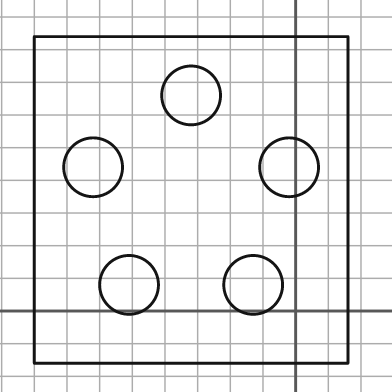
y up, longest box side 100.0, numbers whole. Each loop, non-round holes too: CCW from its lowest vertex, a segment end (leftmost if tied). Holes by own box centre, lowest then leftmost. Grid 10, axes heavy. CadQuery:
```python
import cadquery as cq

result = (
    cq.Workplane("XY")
    .moveTo(-80.0, -16.0)
    .lineTo(16.0, -16.0)
    .lineTo(16.0, 84.0)
    .lineTo(-80.0, 84.0)
    .close()
    .moveTo(-51.0, 8.0)
    .circle(9.0)
    .moveTo(-13.0, 8.0)
    .circle(9.0)
    .moveTo(-62.0, 44.0)
    .circle(9.0)
    .moveTo(-2.0, 44.0)
    .circle(9.0)
    .moveTo(-32.0, 66.0)
    .circle(9.0)
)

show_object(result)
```